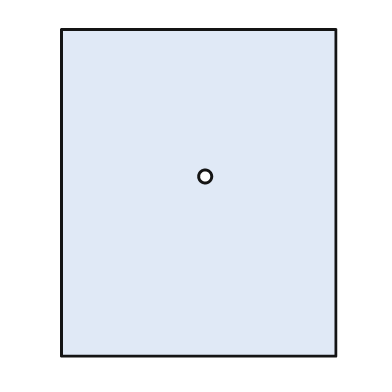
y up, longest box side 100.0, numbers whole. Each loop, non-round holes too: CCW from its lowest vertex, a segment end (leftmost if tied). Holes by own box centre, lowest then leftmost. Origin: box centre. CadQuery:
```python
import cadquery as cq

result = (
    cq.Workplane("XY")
    .moveTo(-42.0, -50.0)
    .lineTo(42.0, -50.0)
    .lineTo(42.0, 50.0)
    .lineTo(-42.0, 50.0)
    .close()
    .moveTo(2.0, 5.0)
    .circle(2.0)
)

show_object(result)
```